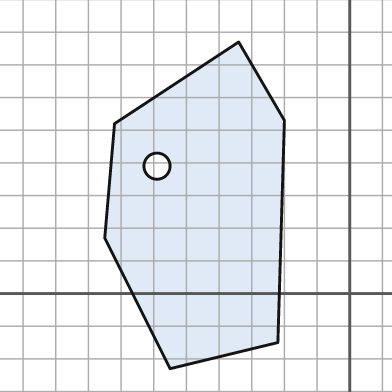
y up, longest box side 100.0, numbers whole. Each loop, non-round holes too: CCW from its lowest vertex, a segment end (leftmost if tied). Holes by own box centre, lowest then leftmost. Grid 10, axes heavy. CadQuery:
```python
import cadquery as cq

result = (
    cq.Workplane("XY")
    .moveTo(-55.0, -23.0)
    .lineTo(-22.0, -15.0)
    .lineTo(-20.0, 53.0)
    .lineTo(-34.0, 77.0)
    .lineTo(-72.0, 52.0)
    .lineTo(-75.0, 17.0)
    .close()
    .moveTo(-59.0, 39.0)
    .circle(4.0)
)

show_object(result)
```